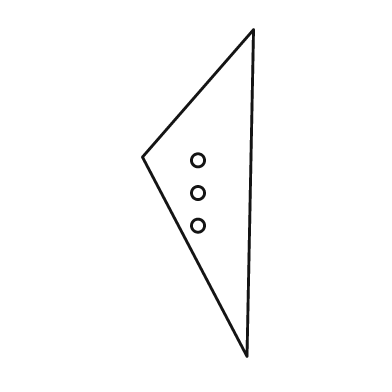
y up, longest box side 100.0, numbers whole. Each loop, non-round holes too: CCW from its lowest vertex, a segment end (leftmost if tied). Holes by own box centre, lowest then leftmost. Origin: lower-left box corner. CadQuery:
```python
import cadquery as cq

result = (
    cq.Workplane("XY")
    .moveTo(32.0, 0.0)
    .lineTo(34.0, 100.0)
    .lineTo(0.0, 61.0)
    .close()
    .moveTo(17.0, 40.0)
    .circle(2.0)
    .moveTo(17.0, 50.0)
    .circle(2.0)
    .moveTo(17.0, 60.0)
    .circle(2.0)
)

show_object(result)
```